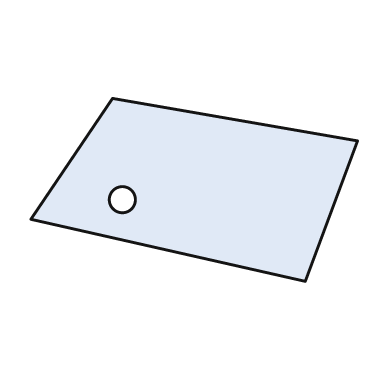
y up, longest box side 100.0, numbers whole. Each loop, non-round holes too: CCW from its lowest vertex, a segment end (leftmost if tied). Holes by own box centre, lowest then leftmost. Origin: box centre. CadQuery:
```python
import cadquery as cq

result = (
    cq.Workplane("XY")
    .moveTo(34.0, -28.0)
    .lineTo(50.0, 15.0)
    .lineTo(-25.0, 28.0)
    .lineTo(-50.0, -9.0)
    .close()
    .moveTo(-22.0, -3.0)
    .circle(4.0)
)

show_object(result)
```